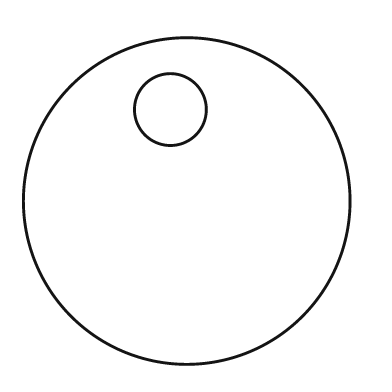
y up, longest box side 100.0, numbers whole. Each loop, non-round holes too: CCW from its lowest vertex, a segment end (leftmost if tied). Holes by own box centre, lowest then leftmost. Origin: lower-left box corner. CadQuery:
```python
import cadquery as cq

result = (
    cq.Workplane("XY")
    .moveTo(50.0, 50.0)
    .circle(50.0)
    .moveTo(45.0, 78.0)
    .circle(11.0)
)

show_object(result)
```